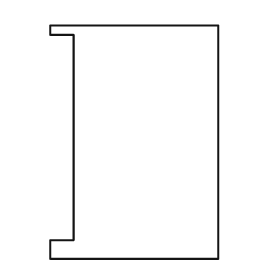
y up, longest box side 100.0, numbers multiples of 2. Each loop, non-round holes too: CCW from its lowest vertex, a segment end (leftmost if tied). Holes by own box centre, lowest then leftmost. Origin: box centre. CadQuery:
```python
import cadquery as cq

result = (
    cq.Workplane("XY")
    .moveTo(-36.0, -50.0)
    .lineTo(36.0, -50.0)
    .lineTo(36.0, 50.0)
    .lineTo(-36.0, 50.0)
    .lineTo(-36.0, 46.0)
    .lineTo(-26.0, 46.0)
    .lineTo(-26.0, -42.0)
    .lineTo(-36.0, -42.0)
    .close()
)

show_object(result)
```